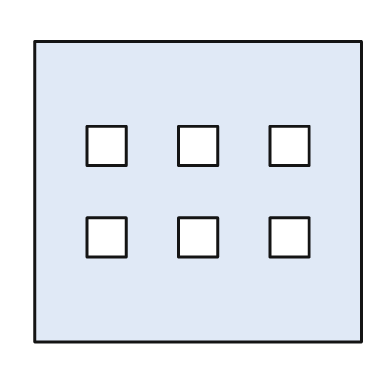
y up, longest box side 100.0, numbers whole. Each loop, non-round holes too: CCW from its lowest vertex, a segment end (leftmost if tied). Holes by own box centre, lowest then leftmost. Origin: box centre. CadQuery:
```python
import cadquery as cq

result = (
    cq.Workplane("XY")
    .moveTo(-50.0, -46.0)
    .lineTo(50.0, -46.0)
    .lineTo(50.0, 46.0)
    .lineTo(-50.0, 46.0)
    .close()
    .moveTo(-34.0, -20.0)
    .lineTo(-22.0, -20.0)
    .lineTo(-22.0, -8.0)
    .lineTo(-34.0, -8.0)
    .close()
    .moveTo(-6.0, -20.0)
    .lineTo(6.0, -20.0)
    .lineTo(6.0, -8.0)
    .lineTo(-6.0, -8.0)
    .close()
    .moveTo(22.0, -20.0)
    .lineTo(34.0, -20.0)
    .lineTo(34.0, -8.0)
    .lineTo(22.0, -8.0)
    .close()
    .moveTo(-34.0, 8.0)
    .lineTo(-22.0, 8.0)
    .lineTo(-22.0, 20.0)
    .lineTo(-34.0, 20.0)
    .close()
    .moveTo(-6.0, 8.0)
    .lineTo(6.0, 8.0)
    .lineTo(6.0, 20.0)
    .lineTo(-6.0, 20.0)
    .close()
    .moveTo(22.0, 8.0)
    .lineTo(34.0, 8.0)
    .lineTo(34.0, 20.0)
    .lineTo(22.0, 20.0)
    .close()
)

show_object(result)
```